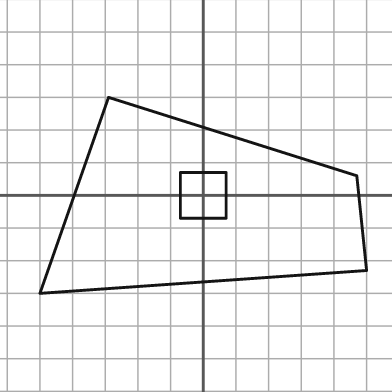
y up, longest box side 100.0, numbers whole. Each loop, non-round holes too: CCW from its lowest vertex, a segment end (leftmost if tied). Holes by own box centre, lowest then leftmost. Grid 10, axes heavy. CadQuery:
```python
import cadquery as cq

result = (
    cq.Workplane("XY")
    .moveTo(-50.0, -30.0)
    .lineTo(50.0, -23.0)
    .lineTo(47.0, 6.0)
    .lineTo(-29.0, 30.0)
    .close()
    .moveTo(-7.0, -7.0)
    .lineTo(7.0, -7.0)
    .lineTo(7.0, 7.0)
    .lineTo(-7.0, 7.0)
    .close()
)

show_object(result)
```